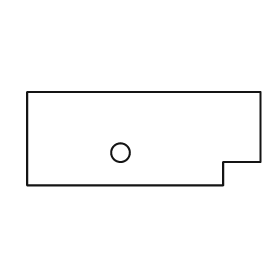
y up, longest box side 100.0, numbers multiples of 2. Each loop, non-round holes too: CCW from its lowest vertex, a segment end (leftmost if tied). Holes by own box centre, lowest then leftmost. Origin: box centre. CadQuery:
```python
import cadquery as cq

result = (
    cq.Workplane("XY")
    .moveTo(-50.0, -20.0)
    .lineTo(34.0, -20.0)
    .lineTo(34.0, -10.0)
    .lineTo(50.0, -10.0)
    .lineTo(50.0, 20.0)
    .lineTo(-50.0, 20.0)
    .close()
    .moveTo(-10.0, -6.0)
    .circle(4.0)
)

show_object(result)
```